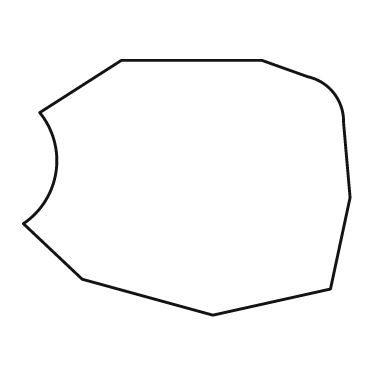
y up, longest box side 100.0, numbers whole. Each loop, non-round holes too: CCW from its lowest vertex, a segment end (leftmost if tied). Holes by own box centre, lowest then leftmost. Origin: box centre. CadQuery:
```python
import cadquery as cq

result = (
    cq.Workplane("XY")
    .moveTo(8.0, -39.0)
    .lineTo(44.0, -31.0)
    .lineTo(50.0, -3.0)
    .lineTo(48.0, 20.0)
    .threePointArc((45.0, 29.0), (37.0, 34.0))
    .lineTo(23.0, 39.0)
    .lineTo(-20.0, 39.0)
    .lineTo(-45.0, 23.0)
    .threePointArc((-40.0, 5.0), (-50.0, -11.0))
    .lineTo(-32.0, -28.0)
    .close()
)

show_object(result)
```